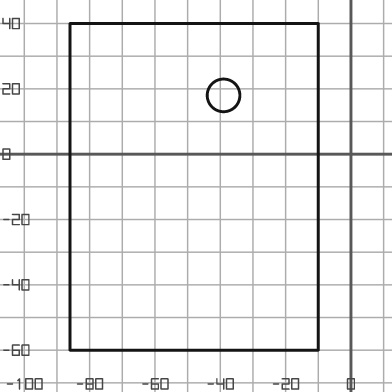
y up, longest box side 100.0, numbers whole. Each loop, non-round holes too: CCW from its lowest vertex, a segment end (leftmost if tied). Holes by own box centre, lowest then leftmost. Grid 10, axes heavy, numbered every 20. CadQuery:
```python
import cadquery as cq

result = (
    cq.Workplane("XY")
    .moveTo(-86.0, -60.0)
    .lineTo(-10.0, -60.0)
    .lineTo(-10.0, 40.0)
    .lineTo(-86.0, 40.0)
    .close()
    .moveTo(-39.0, 18.0)
    .circle(5.0)
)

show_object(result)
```